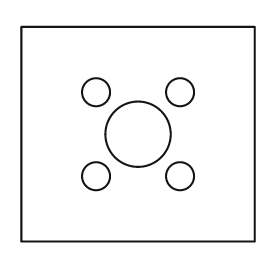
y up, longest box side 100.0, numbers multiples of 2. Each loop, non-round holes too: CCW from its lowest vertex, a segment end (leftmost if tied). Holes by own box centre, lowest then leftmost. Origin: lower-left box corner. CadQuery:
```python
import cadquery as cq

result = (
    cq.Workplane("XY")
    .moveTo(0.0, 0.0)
    .lineTo(100.0, 0.0)
    .lineTo(100.0, 92.0)
    .lineTo(0.0, 92.0)
    .close()
    .moveTo(32.0, 28.0)
    .circle(6.0)
    .moveTo(68.0, 28.0)
    .circle(6.0)
    .moveTo(50.0, 46.0)
    .circle(14.0)
    .moveTo(32.0, 64.0)
    .circle(6.0)
    .moveTo(68.0, 64.0)
    .circle(6.0)
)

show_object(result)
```